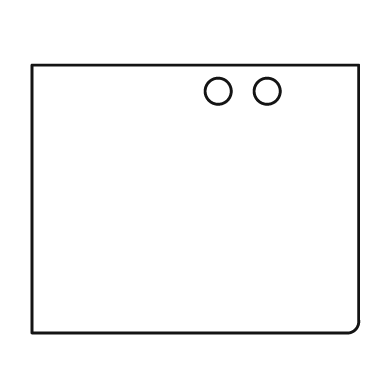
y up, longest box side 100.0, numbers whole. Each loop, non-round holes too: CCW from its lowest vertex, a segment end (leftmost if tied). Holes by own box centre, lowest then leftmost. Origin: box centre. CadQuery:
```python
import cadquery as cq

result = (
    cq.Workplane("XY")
    .moveTo(-50.0, -41.0)
    .lineTo(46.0, -41.0)
    .threePointArc((49.0, -40.0), (50.0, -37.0))
    .lineTo(50.0, 41.0)
    .lineTo(-50.0, 41.0)
    .close()
    .moveTo(7.0, 33.0)
    .circle(4.0)
    .moveTo(22.0, 33.0)
    .circle(4.0)
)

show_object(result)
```